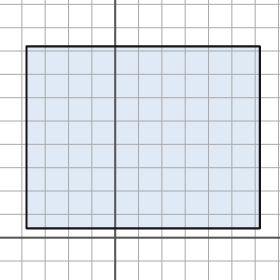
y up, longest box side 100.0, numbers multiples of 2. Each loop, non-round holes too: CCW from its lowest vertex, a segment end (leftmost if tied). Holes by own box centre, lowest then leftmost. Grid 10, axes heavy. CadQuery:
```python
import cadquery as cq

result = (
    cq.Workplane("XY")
    .moveTo(-38.0, 4.0)
    .lineTo(62.0, 4.0)
    .lineTo(62.0, 82.0)
    .lineTo(-38.0, 82.0)
    .close()
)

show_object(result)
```